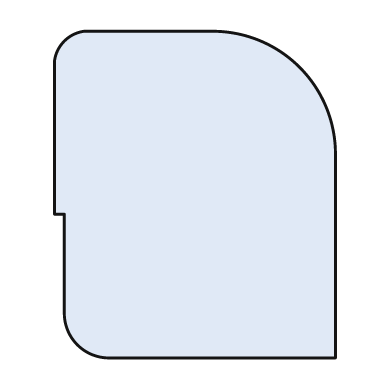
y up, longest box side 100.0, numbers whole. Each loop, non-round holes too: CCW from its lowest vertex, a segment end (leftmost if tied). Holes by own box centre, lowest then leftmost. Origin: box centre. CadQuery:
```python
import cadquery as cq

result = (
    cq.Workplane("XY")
    .moveTo(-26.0, -50.0)
    .lineTo(43.0, -50.0)
    .lineTo(43.0, 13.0)
    .threePointArc((32.0, 39.0), (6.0, 50.0))
    .lineTo(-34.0, 50.0)
    .threePointArc((-40.0, 47.0), (-43.0, 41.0))
    .lineTo(-43.0, -6.0)
    .lineTo(-40.0, -6.0)
    .lineTo(-40.0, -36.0)
    .threePointArc((-36.0, -46.0), (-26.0, -50.0))
    .close()
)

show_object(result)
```